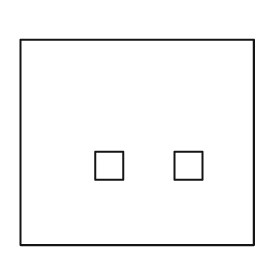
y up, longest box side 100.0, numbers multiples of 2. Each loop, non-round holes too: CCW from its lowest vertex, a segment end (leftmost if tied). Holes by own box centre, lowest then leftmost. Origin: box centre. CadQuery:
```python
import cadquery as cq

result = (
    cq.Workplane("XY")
    .moveTo(-50.0, -44.0)
    .lineTo(50.0, -44.0)
    .lineTo(50.0, 44.0)
    .lineTo(-50.0, 44.0)
    .close()
    .moveTo(-18.0, -16.0)
    .lineTo(-6.0, -16.0)
    .lineTo(-6.0, -4.0)
    .lineTo(-18.0, -4.0)
    .close()
    .moveTo(16.0, -16.0)
    .lineTo(28.0, -16.0)
    .lineTo(28.0, -4.0)
    .lineTo(16.0, -4.0)
    .close()
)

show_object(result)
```